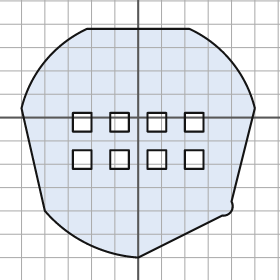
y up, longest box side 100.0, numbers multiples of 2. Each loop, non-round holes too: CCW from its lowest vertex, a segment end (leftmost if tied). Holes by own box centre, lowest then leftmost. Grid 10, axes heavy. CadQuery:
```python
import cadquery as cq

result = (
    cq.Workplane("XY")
    .moveTo(0.0, -60.0)
    .lineTo(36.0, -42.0)
    .threePointArc((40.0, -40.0), (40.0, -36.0))
    .lineTo(50.0, 4.0)
    .threePointArc((40.0, 24.0), (22.0, 38.0))
    .lineTo(-22.0, 38.0)
    .threePointArc((-40.0, 24.0), (-50.0, 4.0))
    .lineTo(-40.0, -40.0)
    .threePointArc((-22.0, -54.0), (0.0, -60.0))
    .close()
    .moveTo(-28.0, -22.0)
    .lineTo(-20.0, -22.0)
    .lineTo(-20.0, -14.0)
    .lineTo(-28.0, -14.0)
    .close()
    .moveTo(-12.0, -22.0)
    .lineTo(-4.0, -22.0)
    .lineTo(-4.0, -14.0)
    .lineTo(-12.0, -14.0)
    .close()
    .moveTo(4.0, -22.0)
    .lineTo(12.0, -22.0)
    .lineTo(12.0, -14.0)
    .lineTo(4.0, -14.0)
    .close()
    .moveTo(20.0, -22.0)
    .lineTo(28.0, -22.0)
    .lineTo(28.0, -14.0)
    .lineTo(20.0, -14.0)
    .close()
    .moveTo(-28.0, -6.0)
    .lineTo(-20.0, -6.0)
    .lineTo(-20.0, 2.0)
    .lineTo(-28.0, 2.0)
    .close()
    .moveTo(-12.0, -6.0)
    .lineTo(-4.0, -6.0)
    .lineTo(-4.0, 2.0)
    .lineTo(-12.0, 2.0)
    .close()
    .moveTo(4.0, -6.0)
    .lineTo(12.0, -6.0)
    .lineTo(12.0, 2.0)
    .lineTo(4.0, 2.0)
    .close()
    .moveTo(20.0, -6.0)
    .lineTo(28.0, -6.0)
    .lineTo(28.0, 2.0)
    .lineTo(20.0, 2.0)
    .close()
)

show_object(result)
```